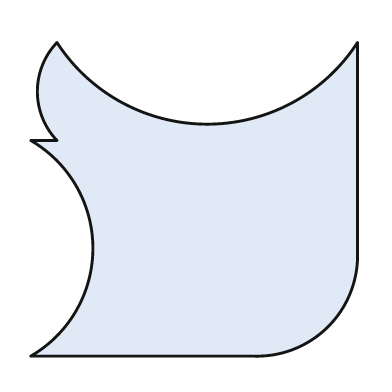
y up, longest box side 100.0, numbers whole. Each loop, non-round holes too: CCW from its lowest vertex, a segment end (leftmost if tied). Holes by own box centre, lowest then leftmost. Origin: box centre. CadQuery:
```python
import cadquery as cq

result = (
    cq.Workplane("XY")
    .moveTo(-50.0, -48.0)
    .lineTo(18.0, -48.0)
    .threePointArc((41.0, -39.0), (50.0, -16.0))
    .lineTo(50.0, 48.0)
    .threePointArc((4.0, 23.0), (-42.0, 48.0))
    .threePointArc((-48.0, 33.0), (-42.0, 18.0))
    .lineTo(-50.0, 18.0)
    .threePointArc((-31.0, -15.0), (-50.0, -48.0))
    .close()
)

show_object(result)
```